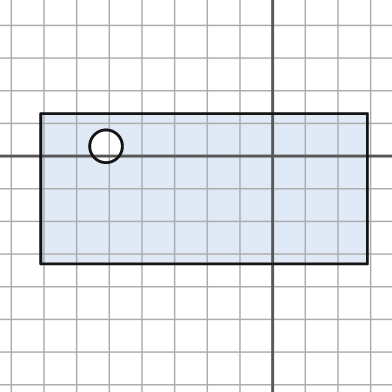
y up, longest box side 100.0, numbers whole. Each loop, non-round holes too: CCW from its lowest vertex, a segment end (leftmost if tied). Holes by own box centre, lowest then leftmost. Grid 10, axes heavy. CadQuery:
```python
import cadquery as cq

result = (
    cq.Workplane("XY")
    .moveTo(-71.0, -33.0)
    .lineTo(29.0, -33.0)
    .lineTo(29.0, 13.0)
    .lineTo(-71.0, 13.0)
    .close()
    .moveTo(-51.0, 3.0)
    .circle(5.0)
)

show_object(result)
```